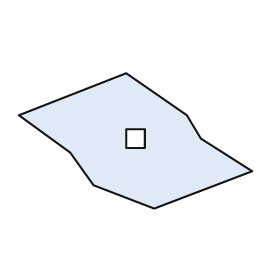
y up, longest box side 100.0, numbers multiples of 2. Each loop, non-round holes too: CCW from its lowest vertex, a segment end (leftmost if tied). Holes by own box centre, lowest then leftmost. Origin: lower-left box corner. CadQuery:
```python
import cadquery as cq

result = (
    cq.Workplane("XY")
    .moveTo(58.0, 0.0)
    .lineTo(100.0, 16.0)
    .lineTo(78.0, 30.0)
    .lineTo(72.0, 40.0)
    .lineTo(46.0, 58.0)
    .lineTo(0.0, 40.0)
    .lineTo(22.0, 24.0)
    .lineTo(32.0, 10.0)
    .close()
    .moveTo(46.0, 26.0)
    .lineTo(54.0, 26.0)
    .lineTo(54.0, 34.0)
    .lineTo(46.0, 34.0)
    .close()
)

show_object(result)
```